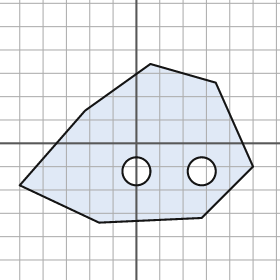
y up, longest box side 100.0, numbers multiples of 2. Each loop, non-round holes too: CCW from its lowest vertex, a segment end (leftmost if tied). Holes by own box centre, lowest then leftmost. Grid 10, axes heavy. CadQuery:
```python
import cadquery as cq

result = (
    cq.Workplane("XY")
    .moveTo(-16.0, -34.0)
    .lineTo(28.0, -32.0)
    .lineTo(50.0, -10.0)
    .lineTo(34.0, 26.0)
    .lineTo(6.0, 34.0)
    .lineTo(-22.0, 14.0)
    .lineTo(-50.0, -18.0)
    .close()
    .moveTo(0.0, -12.0)
    .circle(6.0)
    .moveTo(28.0, -12.0)
    .circle(6.0)
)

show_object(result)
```